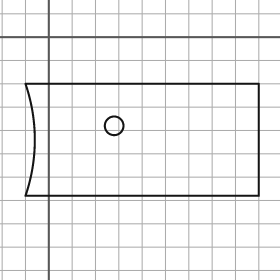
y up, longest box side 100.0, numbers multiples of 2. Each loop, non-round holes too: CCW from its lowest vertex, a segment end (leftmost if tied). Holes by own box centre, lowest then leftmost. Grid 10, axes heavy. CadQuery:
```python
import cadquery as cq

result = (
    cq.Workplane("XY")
    .moveTo(-10.0, -68.0)
    .lineTo(90.0, -68.0)
    .lineTo(90.0, -20.0)
    .lineTo(-10.0, -20.0)
    .threePointArc((-6.0, -44.0), (-10.0, -68.0))
    .close()
    .moveTo(28.0, -38.0)
    .circle(4.0)
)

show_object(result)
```